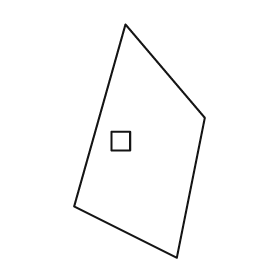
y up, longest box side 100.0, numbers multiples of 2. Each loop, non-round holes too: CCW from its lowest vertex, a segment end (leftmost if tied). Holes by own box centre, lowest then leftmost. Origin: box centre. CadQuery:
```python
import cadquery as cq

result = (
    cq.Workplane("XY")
    .moveTo(16.0, -50.0)
    .lineTo(28.0, 10.0)
    .lineTo(-6.0, 50.0)
    .lineTo(-28.0, -28.0)
    .close()
    .moveTo(-12.0, -4.0)
    .lineTo(-4.0, -4.0)
    .lineTo(-4.0, 4.0)
    .lineTo(-12.0, 4.0)
    .close()
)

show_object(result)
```